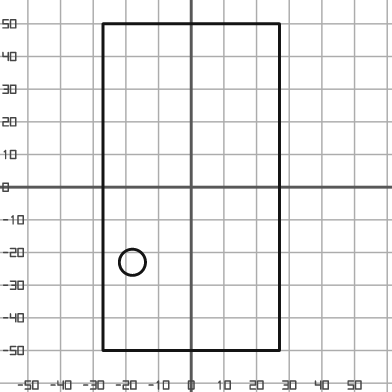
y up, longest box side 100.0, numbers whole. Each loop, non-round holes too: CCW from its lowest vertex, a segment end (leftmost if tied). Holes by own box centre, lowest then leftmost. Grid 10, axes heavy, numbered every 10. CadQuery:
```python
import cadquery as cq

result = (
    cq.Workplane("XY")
    .moveTo(-27.0, -50.0)
    .lineTo(27.0, -50.0)
    .lineTo(27.0, 50.0)
    .lineTo(-27.0, 50.0)
    .close()
    .moveTo(-18.0, -23.0)
    .circle(4.0)
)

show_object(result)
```